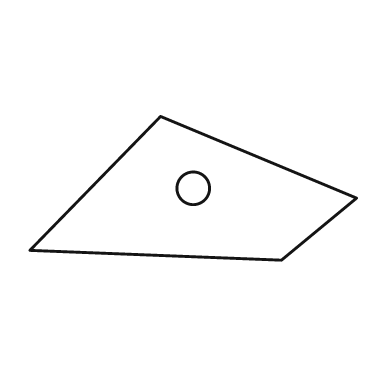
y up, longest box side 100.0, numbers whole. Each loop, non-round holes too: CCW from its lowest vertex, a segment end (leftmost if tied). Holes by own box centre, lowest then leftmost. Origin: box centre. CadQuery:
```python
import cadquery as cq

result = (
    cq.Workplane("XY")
    .moveTo(27.0, -22.0)
    .lineTo(50.0, -3.0)
    .lineTo(-10.0, 22.0)
    .lineTo(-50.0, -19.0)
    .close()
    .moveTo(0.0, 0.0)
    .circle(5.0)
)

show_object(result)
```